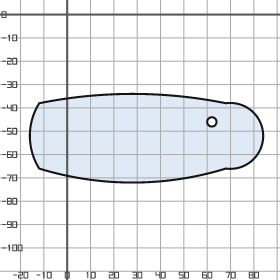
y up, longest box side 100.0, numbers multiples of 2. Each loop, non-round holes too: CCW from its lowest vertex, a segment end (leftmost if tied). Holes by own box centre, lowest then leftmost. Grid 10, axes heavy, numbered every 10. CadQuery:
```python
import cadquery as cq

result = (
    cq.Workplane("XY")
    .moveTo(-12.0, -66.0)
    .threePointArc((28.0, -72.0), (68.0, -66.0))
    .threePointArc((84.0, -52.0), (68.0, -38.0))
    .threePointArc((28.0, -34.0), (-12.0, -38.0))
    .threePointArc((-16.0, -52.0), (-12.0, -66.0))
    .close()
    .moveTo(62.0, -46.0)
    .circle(2.0)
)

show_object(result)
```